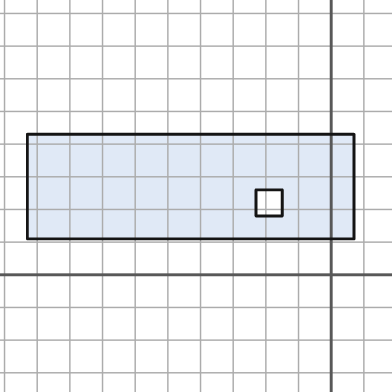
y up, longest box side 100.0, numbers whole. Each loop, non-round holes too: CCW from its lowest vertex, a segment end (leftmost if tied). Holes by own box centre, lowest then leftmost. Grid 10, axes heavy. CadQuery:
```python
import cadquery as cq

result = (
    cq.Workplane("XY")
    .moveTo(-93.0, 11.0)
    .lineTo(7.0, 11.0)
    .lineTo(7.0, 43.0)
    .lineTo(-93.0, 43.0)
    .close()
    .moveTo(-23.0, 18.0)
    .lineTo(-15.0, 18.0)
    .lineTo(-15.0, 26.0)
    .lineTo(-23.0, 26.0)
    .close()
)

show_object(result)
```